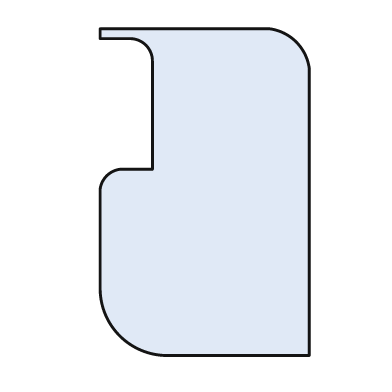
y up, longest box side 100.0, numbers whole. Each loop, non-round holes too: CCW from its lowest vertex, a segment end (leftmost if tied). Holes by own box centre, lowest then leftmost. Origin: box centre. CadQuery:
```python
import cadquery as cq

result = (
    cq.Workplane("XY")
    .moveTo(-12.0, -50.0)
    .lineTo(32.0, -50.0)
    .lineTo(32.0, 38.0)
    .threePointArc((28.0, 46.0), (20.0, 50.0))
    .lineTo(-32.0, 50.0)
    .lineTo(-32.0, 47.0)
    .lineTo(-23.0, 47.0)
    .threePointArc((-18.0, 45.0), (-16.0, 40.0))
    .lineTo(-16.0, 7.0)
    .lineTo(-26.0, 7.0)
    .threePointArc((-30.0, 5.0), (-32.0, 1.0))
    .lineTo(-32.0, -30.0)
    .threePointArc((-26.0, -44.0), (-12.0, -50.0))
    .close()
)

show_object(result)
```